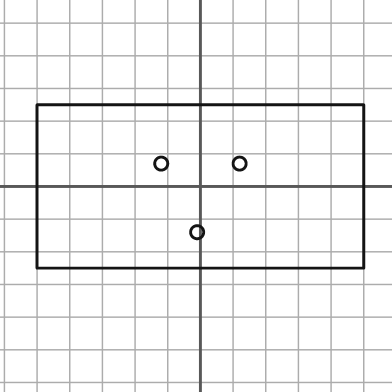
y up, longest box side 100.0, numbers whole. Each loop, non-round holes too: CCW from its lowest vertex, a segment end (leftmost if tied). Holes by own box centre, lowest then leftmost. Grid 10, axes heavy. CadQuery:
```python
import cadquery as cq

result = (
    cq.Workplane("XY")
    .moveTo(-50.0, -25.0)
    .lineTo(50.0, -25.0)
    .lineTo(50.0, 25.0)
    .lineTo(-50.0, 25.0)
    .close()
    .moveTo(-1.0, -14.0)
    .circle(2.0)
    .moveTo(-12.0, 7.0)
    .circle(2.0)
    .moveTo(12.0, 7.0)
    .circle(2.0)
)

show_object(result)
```